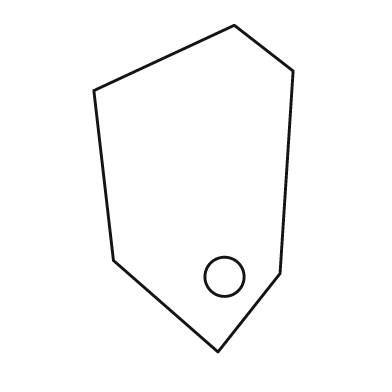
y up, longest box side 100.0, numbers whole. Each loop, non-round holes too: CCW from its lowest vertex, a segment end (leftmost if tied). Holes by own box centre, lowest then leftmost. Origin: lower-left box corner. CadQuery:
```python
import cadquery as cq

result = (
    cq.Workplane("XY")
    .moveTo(38.0, 0.0)
    .lineTo(57.0, 24.0)
    .lineTo(61.0, 86.0)
    .lineTo(43.0, 100.0)
    .lineTo(0.0, 80.0)
    .lineTo(6.0, 28.0)
    .close()
    .moveTo(40.0, 23.0)
    .circle(6.0)
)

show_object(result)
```